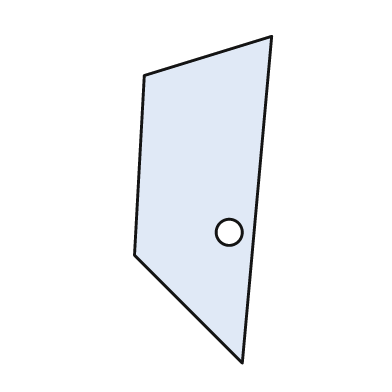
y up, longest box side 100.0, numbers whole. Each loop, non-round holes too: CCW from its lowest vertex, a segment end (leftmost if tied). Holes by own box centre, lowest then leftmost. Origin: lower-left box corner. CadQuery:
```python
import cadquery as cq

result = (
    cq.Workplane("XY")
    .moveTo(33.0, 0.0)
    .lineTo(42.0, 100.0)
    .lineTo(3.0, 88.0)
    .lineTo(0.0, 33.0)
    .close()
    .moveTo(29.0, 40.0)
    .circle(4.0)
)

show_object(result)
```